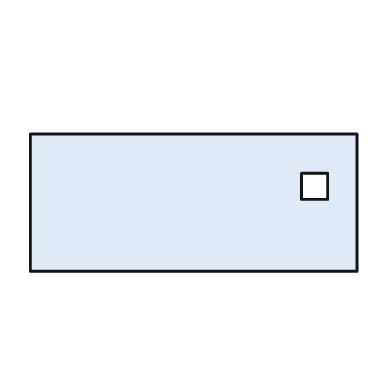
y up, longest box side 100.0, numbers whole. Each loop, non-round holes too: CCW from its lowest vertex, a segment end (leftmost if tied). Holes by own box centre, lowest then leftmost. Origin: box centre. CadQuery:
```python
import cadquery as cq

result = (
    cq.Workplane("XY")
    .moveTo(-50.0, -21.0)
    .lineTo(50.0, -21.0)
    .lineTo(50.0, 21.0)
    .lineTo(-50.0, 21.0)
    .close()
    .moveTo(33.0, 1.0)
    .lineTo(41.0, 1.0)
    .lineTo(41.0, 9.0)
    .lineTo(33.0, 9.0)
    .close()
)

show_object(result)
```